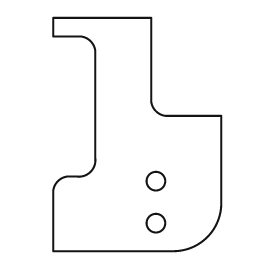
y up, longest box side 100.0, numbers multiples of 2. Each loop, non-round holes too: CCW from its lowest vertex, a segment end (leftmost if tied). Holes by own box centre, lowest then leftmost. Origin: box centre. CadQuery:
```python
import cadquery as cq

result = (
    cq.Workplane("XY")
    .moveTo(-36.0, -50.0)
    .lineTo(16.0, -50.0)
    .threePointArc((30.0, -44.0), (36.0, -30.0))
    .lineTo(36.0, 8.0)
    .lineTo(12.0, 8.0)
    .threePointArc((8.0, 10.0), (6.0, 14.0))
    .lineTo(6.0, 50.0)
    .lineTo(-36.0, 50.0)
    .lineTo(-36.0, 42.0)
    .lineTo(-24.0, 42.0)
    .threePointArc((-20.0, 40.0), (-18.0, 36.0))
    .lineTo(-18.0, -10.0)
    .threePointArc((-20.0, -16.0), (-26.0, -18.0))
    .lineTo(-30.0, -18.0)
    .threePointArc((-34.0, -20.0), (-36.0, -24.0))
    .close()
    .moveTo(8.0, -38.0)
    .circle(4.0)
    .moveTo(8.0, -20.0)
    .circle(4.0)
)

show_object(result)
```